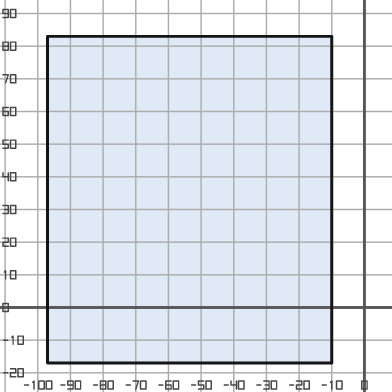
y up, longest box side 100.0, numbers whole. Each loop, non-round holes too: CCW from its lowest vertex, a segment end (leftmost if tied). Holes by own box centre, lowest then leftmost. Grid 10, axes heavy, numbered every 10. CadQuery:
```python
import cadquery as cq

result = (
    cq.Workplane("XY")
    .moveTo(-97.0, -17.0)
    .lineTo(-10.0, -17.0)
    .lineTo(-10.0, 83.0)
    .lineTo(-97.0, 83.0)
    .close()
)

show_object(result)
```